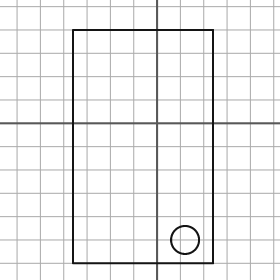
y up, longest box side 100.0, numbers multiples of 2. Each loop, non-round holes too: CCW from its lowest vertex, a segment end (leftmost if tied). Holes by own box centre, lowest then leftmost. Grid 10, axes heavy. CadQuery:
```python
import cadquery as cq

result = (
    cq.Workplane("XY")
    .moveTo(-36.0, -60.0)
    .lineTo(24.0, -60.0)
    .lineTo(24.0, 40.0)
    .lineTo(-36.0, 40.0)
    .close()
    .moveTo(12.0, -50.0)
    .circle(6.0)
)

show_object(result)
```